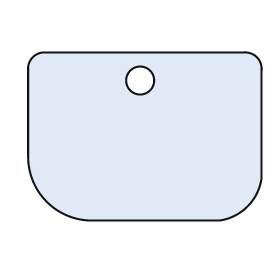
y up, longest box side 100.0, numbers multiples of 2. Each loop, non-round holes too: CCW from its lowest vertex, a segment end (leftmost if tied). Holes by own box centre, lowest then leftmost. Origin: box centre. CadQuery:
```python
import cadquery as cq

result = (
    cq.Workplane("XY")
    .moveTo(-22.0, -36.0)
    .lineTo(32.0, -36.0)
    .threePointArc((44.0, -30.0), (50.0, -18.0))
    .lineTo(50.0, 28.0)
    .threePointArc((48.0, 34.0), (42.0, 36.0))
    .lineTo(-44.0, 36.0)
    .threePointArc((-48.0, 34.0), (-50.0, 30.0))
    .lineTo(-50.0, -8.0)
    .threePointArc((-42.0, -28.0), (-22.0, -36.0))
    .close()
    .moveTo(-2.0, 24.0)
    .circle(6.0)
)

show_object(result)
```